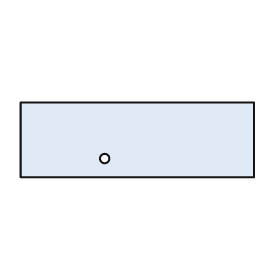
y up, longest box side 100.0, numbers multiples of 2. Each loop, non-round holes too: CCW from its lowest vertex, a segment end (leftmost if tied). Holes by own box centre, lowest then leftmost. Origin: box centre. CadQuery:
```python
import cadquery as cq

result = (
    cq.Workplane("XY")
    .moveTo(-50.0, -16.0)
    .lineTo(50.0, -16.0)
    .lineTo(50.0, 16.0)
    .lineTo(-50.0, 16.0)
    .close()
    .moveTo(-14.0, -8.0)
    .circle(2.0)
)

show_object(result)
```